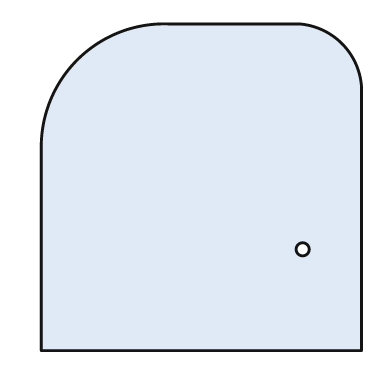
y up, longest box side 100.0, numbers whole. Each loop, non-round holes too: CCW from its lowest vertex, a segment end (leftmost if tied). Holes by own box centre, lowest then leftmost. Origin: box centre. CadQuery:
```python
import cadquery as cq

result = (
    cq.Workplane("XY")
    .moveTo(-49.0, -50.0)
    .lineTo(49.0, -50.0)
    .lineTo(49.0, 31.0)
    .threePointArc((43.0, 44.0), (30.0, 50.0))
    .lineTo(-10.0, 50.0)
    .threePointArc((-38.0, 39.0), (-49.0, 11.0))
    .close()
    .moveTo(31.0, -19.0)
    .circle(2.0)
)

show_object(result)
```